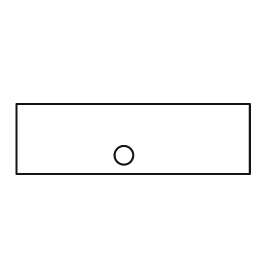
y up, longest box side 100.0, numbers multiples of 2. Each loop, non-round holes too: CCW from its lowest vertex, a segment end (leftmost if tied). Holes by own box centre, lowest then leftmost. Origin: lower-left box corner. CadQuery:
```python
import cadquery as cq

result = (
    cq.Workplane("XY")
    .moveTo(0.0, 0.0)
    .lineTo(100.0, 0.0)
    .lineTo(100.0, 30.0)
    .lineTo(0.0, 30.0)
    .close()
    .moveTo(46.0, 8.0)
    .circle(4.0)
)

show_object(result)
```